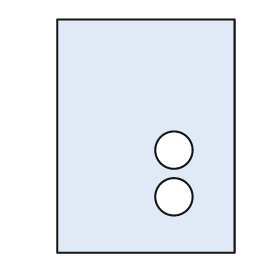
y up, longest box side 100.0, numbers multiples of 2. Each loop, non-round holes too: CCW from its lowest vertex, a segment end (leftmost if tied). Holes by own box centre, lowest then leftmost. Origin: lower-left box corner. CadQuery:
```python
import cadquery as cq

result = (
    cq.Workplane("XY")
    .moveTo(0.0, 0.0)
    .lineTo(76.0, 0.0)
    .lineTo(76.0, 100.0)
    .lineTo(0.0, 100.0)
    .close()
    .moveTo(50.0, 24.0)
    .circle(8.0)
    .moveTo(50.0, 44.0)
    .circle(8.0)
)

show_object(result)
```